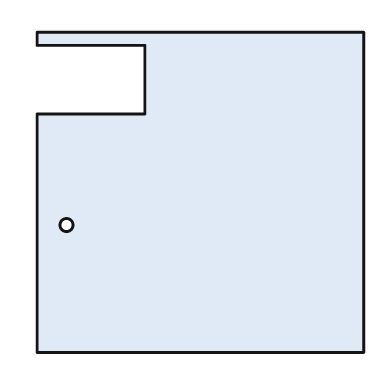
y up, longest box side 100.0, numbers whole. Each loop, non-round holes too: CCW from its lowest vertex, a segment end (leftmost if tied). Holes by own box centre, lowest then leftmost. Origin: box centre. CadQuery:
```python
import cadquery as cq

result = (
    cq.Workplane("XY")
    .moveTo(-50.0, -49.0)
    .lineTo(50.0, -49.0)
    .lineTo(50.0, 49.0)
    .lineTo(-50.0, 49.0)
    .lineTo(-50.0, 45.0)
    .lineTo(-17.0, 45.0)
    .lineTo(-17.0, 24.0)
    .lineTo(-50.0, 24.0)
    .close()
    .moveTo(-41.0, -10.0)
    .circle(2.0)
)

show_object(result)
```